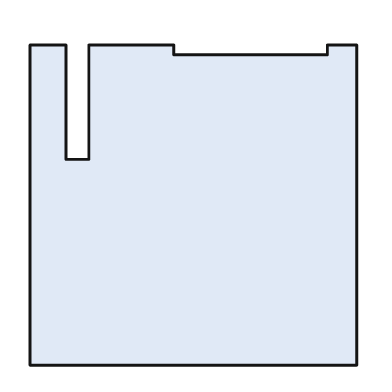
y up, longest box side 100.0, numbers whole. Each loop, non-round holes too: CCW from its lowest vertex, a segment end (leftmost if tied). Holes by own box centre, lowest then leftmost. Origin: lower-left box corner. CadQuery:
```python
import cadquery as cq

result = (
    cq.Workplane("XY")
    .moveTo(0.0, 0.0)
    .lineTo(100.0, 0.0)
    .lineTo(100.0, 98.0)
    .lineTo(91.0, 98.0)
    .lineTo(91.0, 95.0)
    .lineTo(44.0, 95.0)
    .lineTo(44.0, 98.0)
    .lineTo(18.0, 98.0)
    .lineTo(18.0, 63.0)
    .lineTo(11.0, 63.0)
    .lineTo(11.0, 98.0)
    .lineTo(0.0, 98.0)
    .close()
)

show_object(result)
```